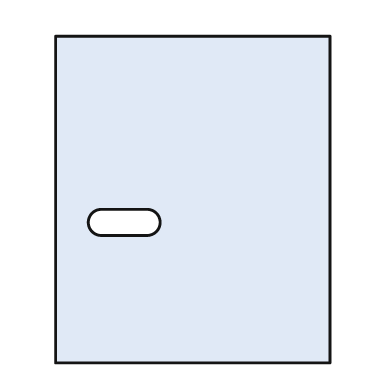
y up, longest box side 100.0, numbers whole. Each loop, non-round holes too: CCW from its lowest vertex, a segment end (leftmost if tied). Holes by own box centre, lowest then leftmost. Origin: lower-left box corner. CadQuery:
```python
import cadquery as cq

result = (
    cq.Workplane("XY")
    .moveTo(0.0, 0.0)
    .lineTo(84.0, 0.0)
    .lineTo(84.0, 100.0)
    .lineTo(0.0, 100.0)
    .close()
    .moveTo(14.0, 39.0)
    .lineTo(28.0, 39.0)
    .threePointArc((32.0, 43.0), (28.0, 47.0))
    .lineTo(14.0, 47.0)
    .threePointArc((10.0, 43.0), (14.0, 39.0))
    .close()
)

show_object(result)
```